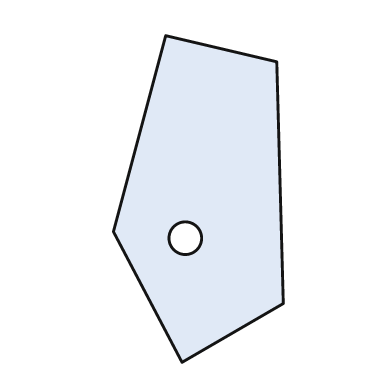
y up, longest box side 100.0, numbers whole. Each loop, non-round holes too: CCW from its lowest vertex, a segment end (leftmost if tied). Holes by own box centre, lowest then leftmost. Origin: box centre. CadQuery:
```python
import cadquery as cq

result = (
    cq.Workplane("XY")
    .moveTo(-5.0, -50.0)
    .lineTo(26.0, -32.0)
    .lineTo(24.0, 42.0)
    .lineTo(-10.0, 50.0)
    .lineTo(-26.0, -10.0)
    .close()
    .moveTo(-4.0, -12.0)
    .circle(5.0)
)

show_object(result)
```